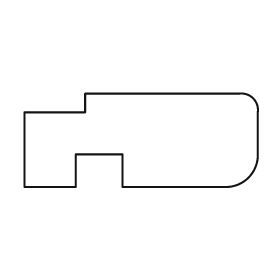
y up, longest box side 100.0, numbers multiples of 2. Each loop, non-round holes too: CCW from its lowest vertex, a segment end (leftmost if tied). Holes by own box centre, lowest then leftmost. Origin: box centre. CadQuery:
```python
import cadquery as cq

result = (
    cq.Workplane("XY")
    .moveTo(-50.0, -20.0)
    .lineTo(-28.0, -20.0)
    .lineTo(-28.0, -6.0)
    .lineTo(-8.0, -6.0)
    .lineTo(-8.0, -20.0)
    .lineTo(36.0, -20.0)
    .threePointArc((46.0, -16.0), (50.0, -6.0))
    .lineTo(50.0, 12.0)
    .threePointArc((48.0, 18.0), (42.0, 20.0))
    .lineTo(-24.0, 20.0)
    .lineTo(-24.0, 12.0)
    .lineTo(-50.0, 12.0)
    .close()
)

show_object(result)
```